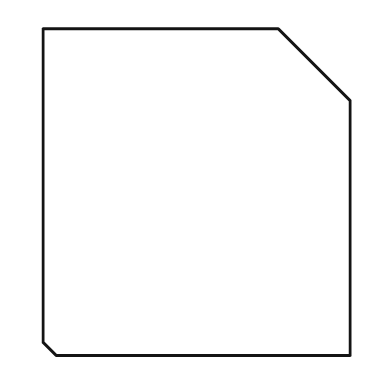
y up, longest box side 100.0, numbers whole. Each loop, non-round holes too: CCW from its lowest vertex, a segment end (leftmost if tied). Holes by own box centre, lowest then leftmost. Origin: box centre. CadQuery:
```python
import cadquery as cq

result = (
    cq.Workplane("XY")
    .moveTo(-43.0, -50.0)
    .lineTo(47.0, -50.0)
    .lineTo(47.0, 28.0)
    .lineTo(25.0, 50.0)
    .lineTo(-47.0, 50.0)
    .lineTo(-47.0, -46.0)
    .close()
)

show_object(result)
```